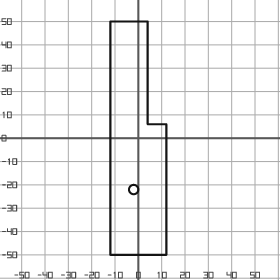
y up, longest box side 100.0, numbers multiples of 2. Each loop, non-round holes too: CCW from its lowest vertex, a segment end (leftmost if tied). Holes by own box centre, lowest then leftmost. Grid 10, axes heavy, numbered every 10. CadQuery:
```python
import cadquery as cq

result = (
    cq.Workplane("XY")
    .moveTo(-12.0, -50.0)
    .lineTo(12.0, -50.0)
    .lineTo(12.0, 6.0)
    .lineTo(4.0, 6.0)
    .lineTo(4.0, 50.0)
    .lineTo(-12.0, 50.0)
    .close()
    .moveTo(-2.0, -22.0)
    .circle(2.0)
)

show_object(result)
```